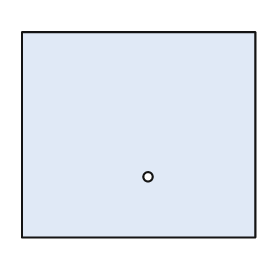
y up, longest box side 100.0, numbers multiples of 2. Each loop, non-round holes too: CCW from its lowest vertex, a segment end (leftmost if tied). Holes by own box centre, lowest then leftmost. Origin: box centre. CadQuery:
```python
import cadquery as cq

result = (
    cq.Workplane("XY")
    .moveTo(-50.0, -44.0)
    .lineTo(50.0, -44.0)
    .lineTo(50.0, 44.0)
    .lineTo(-50.0, 44.0)
    .close()
    .moveTo(4.0, -18.0)
    .circle(2.0)
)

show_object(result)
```